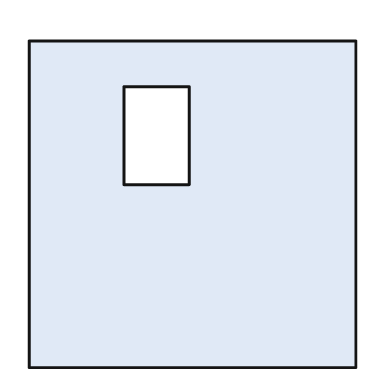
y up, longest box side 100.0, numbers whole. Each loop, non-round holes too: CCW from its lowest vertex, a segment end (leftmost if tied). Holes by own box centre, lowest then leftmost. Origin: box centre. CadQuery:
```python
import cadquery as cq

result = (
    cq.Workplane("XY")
    .moveTo(-50.0, -50.0)
    .lineTo(50.0, -50.0)
    .lineTo(50.0, 50.0)
    .lineTo(-50.0, 50.0)
    .close()
    .moveTo(-21.0, 6.0)
    .lineTo(-1.0, 6.0)
    .lineTo(-1.0, 36.0)
    .lineTo(-21.0, 36.0)
    .close()
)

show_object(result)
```